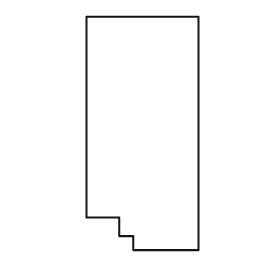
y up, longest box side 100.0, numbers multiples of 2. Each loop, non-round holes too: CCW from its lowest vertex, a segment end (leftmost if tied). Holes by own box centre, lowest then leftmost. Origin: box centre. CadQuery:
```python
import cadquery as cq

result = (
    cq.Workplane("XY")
    .moveTo(-4.0, -50.0)
    .lineTo(24.0, -50.0)
    .lineTo(24.0, 50.0)
    .lineTo(-24.0, 50.0)
    .lineTo(-24.0, -36.0)
    .lineTo(-10.0, -36.0)
    .lineTo(-10.0, -44.0)
    .lineTo(-4.0, -44.0)
    .close()
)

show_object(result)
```